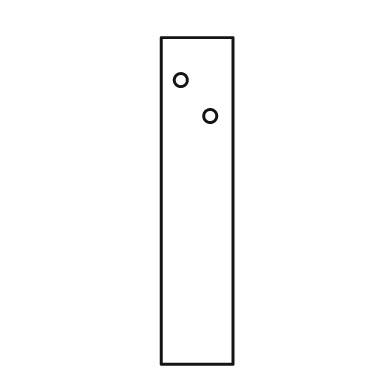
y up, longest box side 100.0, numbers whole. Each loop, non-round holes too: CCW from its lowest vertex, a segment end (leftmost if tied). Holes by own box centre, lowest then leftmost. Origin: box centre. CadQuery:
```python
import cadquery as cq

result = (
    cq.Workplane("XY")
    .moveTo(-11.0, -50.0)
    .lineTo(11.0, -50.0)
    .lineTo(11.0, 50.0)
    .lineTo(-11.0, 50.0)
    .close()
    .moveTo(4.0, 26.0)
    .circle(2.0)
    .moveTo(-5.0, 37.0)
    .circle(2.0)
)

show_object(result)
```